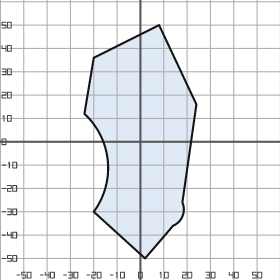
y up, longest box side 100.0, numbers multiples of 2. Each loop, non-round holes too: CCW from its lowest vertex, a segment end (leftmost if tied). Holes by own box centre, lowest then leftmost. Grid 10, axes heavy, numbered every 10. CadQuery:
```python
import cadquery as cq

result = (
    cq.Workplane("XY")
    .moveTo(2.0, -50.0)
    .lineTo(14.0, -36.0)
    .threePointArc((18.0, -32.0), (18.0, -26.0))
    .lineTo(24.0, 16.0)
    .lineTo(8.0, 50.0)
    .lineTo(-20.0, 36.0)
    .lineTo(-24.0, 12.0)
    .threePointArc((-14.0, -8.0), (-20.0, -30.0))
    .close()
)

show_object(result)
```